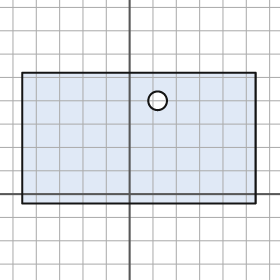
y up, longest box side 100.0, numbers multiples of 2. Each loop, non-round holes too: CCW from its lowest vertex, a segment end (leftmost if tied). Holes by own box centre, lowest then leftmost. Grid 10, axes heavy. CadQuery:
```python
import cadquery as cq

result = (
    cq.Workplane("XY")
    .moveTo(-46.0, -4.0)
    .lineTo(54.0, -4.0)
    .lineTo(54.0, 52.0)
    .lineTo(-46.0, 52.0)
    .close()
    .moveTo(12.0, 40.0)
    .circle(4.0)
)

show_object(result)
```